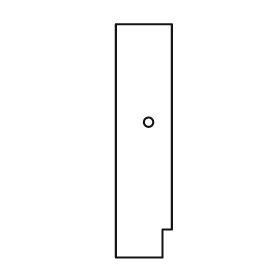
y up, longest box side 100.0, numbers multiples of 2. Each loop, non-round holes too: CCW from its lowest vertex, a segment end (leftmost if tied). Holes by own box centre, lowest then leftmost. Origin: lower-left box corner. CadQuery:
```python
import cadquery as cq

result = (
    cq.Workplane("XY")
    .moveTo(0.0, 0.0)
    .lineTo(20.0, 0.0)
    .lineTo(20.0, 12.0)
    .lineTo(24.0, 12.0)
    .lineTo(24.0, 100.0)
    .lineTo(0.0, 100.0)
    .close()
    .moveTo(14.0, 58.0)
    .circle(2.0)
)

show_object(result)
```